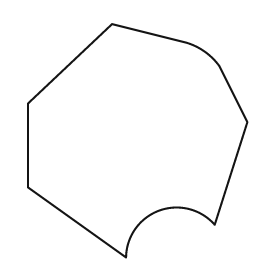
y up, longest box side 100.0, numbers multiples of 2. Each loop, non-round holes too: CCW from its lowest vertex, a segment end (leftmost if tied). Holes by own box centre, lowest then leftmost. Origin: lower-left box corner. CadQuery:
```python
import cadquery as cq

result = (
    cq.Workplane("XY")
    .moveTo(42.0, 0.0)
    .threePointArc((56.0, 20.0), (80.0, 14.0))
    .lineTo(94.0, 58.0)
    .lineTo(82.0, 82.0)
    .threePointArc((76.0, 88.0), (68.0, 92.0))
    .lineTo(36.0, 100.0)
    .lineTo(0.0, 66.0)
    .lineTo(0.0, 30.0)
    .close()
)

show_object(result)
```